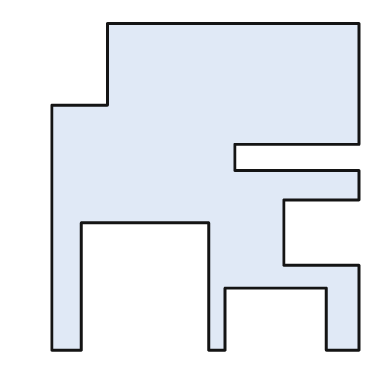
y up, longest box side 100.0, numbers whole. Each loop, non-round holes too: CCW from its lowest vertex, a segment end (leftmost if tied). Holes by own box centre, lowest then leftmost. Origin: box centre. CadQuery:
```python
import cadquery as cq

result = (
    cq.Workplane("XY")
    .moveTo(-47.0, -50.0)
    .lineTo(-38.0, -50.0)
    .lineTo(-38.0, -11.0)
    .lineTo(1.0, -11.0)
    .lineTo(1.0, -50.0)
    .lineTo(6.0, -50.0)
    .lineTo(6.0, -31.0)
    .lineTo(37.0, -31.0)
    .lineTo(37.0, -50.0)
    .lineTo(47.0, -50.0)
    .lineTo(47.0, -24.0)
    .lineTo(24.0, -24.0)
    .lineTo(24.0, -4.0)
    .lineTo(47.0, -4.0)
    .lineTo(47.0, 5.0)
    .lineTo(9.0, 5.0)
    .lineTo(9.0, 13.0)
    .lineTo(47.0, 13.0)
    .lineTo(47.0, 50.0)
    .lineTo(-30.0, 50.0)
    .lineTo(-30.0, 25.0)
    .lineTo(-47.0, 25.0)
    .close()
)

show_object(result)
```